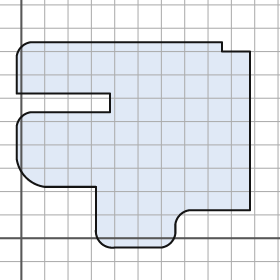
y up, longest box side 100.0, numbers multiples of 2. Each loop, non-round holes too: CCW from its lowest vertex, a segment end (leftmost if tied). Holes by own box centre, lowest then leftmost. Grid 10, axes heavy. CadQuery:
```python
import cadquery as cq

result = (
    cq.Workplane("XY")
    .moveTo(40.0, -4.0)
    .lineTo(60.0, -4.0)
    .threePointArc((64.0, -2.0), (66.0, 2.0))
    .lineTo(66.0, 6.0)
    .threePointArc((68.0, 10.0), (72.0, 12.0))
    .lineTo(98.0, 12.0)
    .lineTo(98.0, 80.0)
    .lineTo(86.0, 80.0)
    .lineTo(86.0, 84.0)
    .lineTo(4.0, 84.0)
    .threePointArc((0.0, 82.0), (-2.0, 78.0))
    .lineTo(-2.0, 62.0)
    .lineTo(38.0, 62.0)
    .lineTo(38.0, 54.0)
    .lineTo(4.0, 54.0)
    .threePointArc((0.0, 52.0), (-2.0, 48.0))
    .lineTo(-2.0, 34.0)
    .threePointArc((2.0, 26.0), (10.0, 22.0))
    .lineTo(32.0, 22.0)
    .lineTo(32.0, 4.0)
    .threePointArc((34.0, -2.0), (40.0, -4.0))
    .close()
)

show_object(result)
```